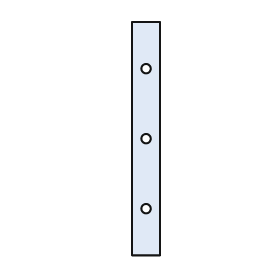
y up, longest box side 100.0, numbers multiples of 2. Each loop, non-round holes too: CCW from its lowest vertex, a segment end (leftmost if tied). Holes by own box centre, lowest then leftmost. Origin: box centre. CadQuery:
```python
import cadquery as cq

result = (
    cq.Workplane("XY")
    .moveTo(-6.0, -50.0)
    .lineTo(6.0, -50.0)
    .lineTo(6.0, 50.0)
    .lineTo(-6.0, 50.0)
    .close()
    .moveTo(0.0, -30.0)
    .circle(2.0)
    .moveTo(0.0, 0.0)
    .circle(2.0)
    .moveTo(0.0, 30.0)
    .circle(2.0)
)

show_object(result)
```